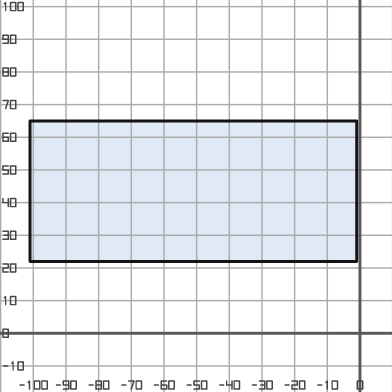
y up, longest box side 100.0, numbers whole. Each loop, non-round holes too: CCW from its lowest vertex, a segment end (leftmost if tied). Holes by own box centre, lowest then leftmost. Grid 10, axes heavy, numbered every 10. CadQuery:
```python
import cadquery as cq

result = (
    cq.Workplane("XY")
    .moveTo(-101.0, 22.0)
    .lineTo(-1.0, 22.0)
    .lineTo(-1.0, 65.0)
    .lineTo(-101.0, 65.0)
    .close()
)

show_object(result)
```